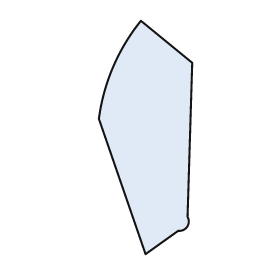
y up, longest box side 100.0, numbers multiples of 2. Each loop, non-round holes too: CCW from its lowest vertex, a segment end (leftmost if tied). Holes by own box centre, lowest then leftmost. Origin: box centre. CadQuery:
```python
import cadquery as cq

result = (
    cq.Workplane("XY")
    .moveTo(0.0, -50.0)
    .lineTo(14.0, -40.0)
    .threePointArc((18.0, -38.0), (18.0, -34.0))
    .lineTo(20.0, 32.0)
    .lineTo(-2.0, 50.0)
    .threePointArc((-14.0, 30.0), (-20.0, 8.0))
    .close()
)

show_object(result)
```